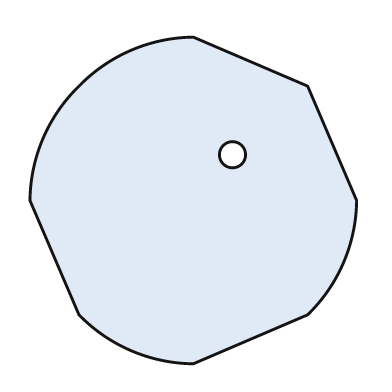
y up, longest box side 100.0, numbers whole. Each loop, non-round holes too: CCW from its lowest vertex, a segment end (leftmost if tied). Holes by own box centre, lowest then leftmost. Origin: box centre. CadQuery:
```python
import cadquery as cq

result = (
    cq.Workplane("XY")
    .moveTo(0.0, -50.0)
    .lineTo(35.0, -35.0)
    .threePointArc((46.0, -19.0), (50.0, 0.0))
    .lineTo(35.0, 35.0)
    .lineTo(0.0, 50.0)
    .threePointArc((-19.0, 46.0), (-35.0, 35.0))
    .threePointArc((-46.0, 19.0), (-50.0, 0.0))
    .lineTo(-35.0, -35.0)
    .threePointArc((-19.0, -46.0), (0.0, -50.0))
    .close()
    .moveTo(12.0, 14.0)
    .circle(4.0)
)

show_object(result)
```